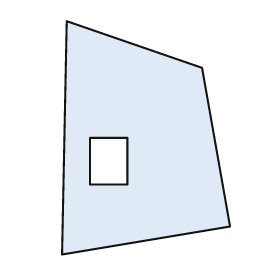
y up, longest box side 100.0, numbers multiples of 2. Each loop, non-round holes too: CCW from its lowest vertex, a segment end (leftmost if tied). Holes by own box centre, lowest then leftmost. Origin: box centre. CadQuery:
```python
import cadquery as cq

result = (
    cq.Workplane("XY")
    .moveTo(-36.0, -50.0)
    .lineTo(36.0, -38.0)
    .lineTo(24.0, 30.0)
    .lineTo(-34.0, 50.0)
    .close()
    .moveTo(-24.0, -20.0)
    .lineTo(-8.0, -20.0)
    .lineTo(-8.0, 0.0)
    .lineTo(-24.0, 0.0)
    .close()
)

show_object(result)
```